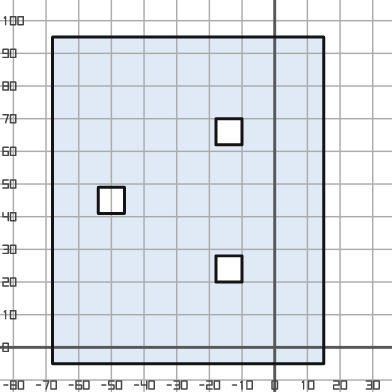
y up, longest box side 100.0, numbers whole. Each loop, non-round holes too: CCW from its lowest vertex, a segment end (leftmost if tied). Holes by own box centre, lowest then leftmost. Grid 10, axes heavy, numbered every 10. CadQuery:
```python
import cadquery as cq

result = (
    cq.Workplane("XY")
    .moveTo(-68.0, -5.0)
    .lineTo(15.0, -5.0)
    .lineTo(15.0, 95.0)
    .lineTo(-68.0, 95.0)
    .close()
    .moveTo(-18.0, 20.0)
    .lineTo(-10.0, 20.0)
    .lineTo(-10.0, 28.0)
    .lineTo(-18.0, 28.0)
    .close()
    .moveTo(-54.0, 41.0)
    .lineTo(-46.0, 41.0)
    .lineTo(-46.0, 49.0)
    .lineTo(-54.0, 49.0)
    .close()
    .moveTo(-18.0, 62.0)
    .lineTo(-10.0, 62.0)
    .lineTo(-10.0, 70.0)
    .lineTo(-18.0, 70.0)
    .close()
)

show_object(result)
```